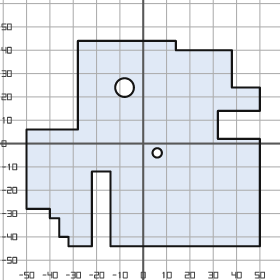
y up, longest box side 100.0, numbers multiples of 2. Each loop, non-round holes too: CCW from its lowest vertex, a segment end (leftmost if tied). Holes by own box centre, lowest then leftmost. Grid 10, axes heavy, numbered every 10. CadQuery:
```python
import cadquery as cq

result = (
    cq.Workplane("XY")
    .moveTo(-32.0, -44.0)
    .lineTo(-22.0, -44.0)
    .lineTo(-22.0, -12.0)
    .lineTo(-14.0, -12.0)
    .lineTo(-14.0, -44.0)
    .lineTo(50.0, -44.0)
    .lineTo(50.0, 2.0)
    .lineTo(32.0, 2.0)
    .lineTo(32.0, 14.0)
    .lineTo(50.0, 14.0)
    .lineTo(50.0, 24.0)
    .lineTo(38.0, 24.0)
    .lineTo(38.0, 40.0)
    .lineTo(14.0, 40.0)
    .lineTo(14.0, 44.0)
    .lineTo(-28.0, 44.0)
    .lineTo(-28.0, 6.0)
    .lineTo(-50.0, 6.0)
    .lineTo(-50.0, -28.0)
    .lineTo(-40.0, -28.0)
    .lineTo(-40.0, -32.0)
    .lineTo(-36.0, -32.0)
    .lineTo(-36.0, -40.0)
    .lineTo(-32.0, -40.0)
    .close()
    .moveTo(6.0, -4.0)
    .circle(2.0)
    .moveTo(-8.0, 24.0)
    .circle(4.0)
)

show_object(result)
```